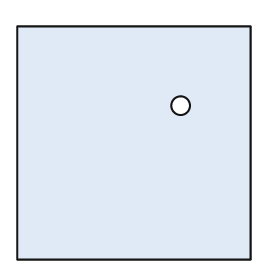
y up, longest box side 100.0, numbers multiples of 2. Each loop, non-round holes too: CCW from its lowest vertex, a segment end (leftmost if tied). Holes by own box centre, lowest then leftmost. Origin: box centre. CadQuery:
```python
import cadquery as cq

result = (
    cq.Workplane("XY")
    .moveTo(-50.0, -50.0)
    .lineTo(50.0, -50.0)
    .lineTo(50.0, 50.0)
    .lineTo(-50.0, 50.0)
    .close()
    .moveTo(20.0, 16.0)
    .circle(4.0)
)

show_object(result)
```